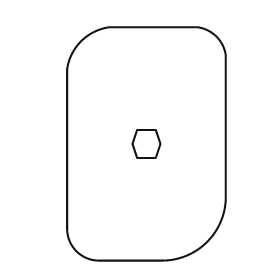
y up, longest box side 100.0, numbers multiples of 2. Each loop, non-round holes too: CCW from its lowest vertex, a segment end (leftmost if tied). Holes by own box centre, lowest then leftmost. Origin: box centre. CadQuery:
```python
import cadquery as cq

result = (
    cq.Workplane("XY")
    .moveTo(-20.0, -50.0)
    .lineTo(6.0, -50.0)
    .threePointArc((26.0, -42.0), (34.0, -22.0))
    .lineTo(34.0, 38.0)
    .threePointArc((30.0, 46.0), (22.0, 50.0))
    .lineTo(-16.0, 50.0)
    .threePointArc((-28.0, 44.0), (-34.0, 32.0))
    .lineTo(-34.0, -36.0)
    .threePointArc((-30.0, -46.0), (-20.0, -50.0))
    .close()
    .moveTo(-4.0, -6.0)
    .lineTo(4.0, -6.0)
    .lineTo(6.0, 0.0)
    .lineTo(4.0, 6.0)
    .lineTo(-4.0, 6.0)
    .lineTo(-6.0, 0.0)
    .close()
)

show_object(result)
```